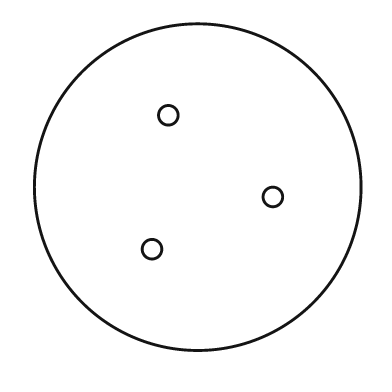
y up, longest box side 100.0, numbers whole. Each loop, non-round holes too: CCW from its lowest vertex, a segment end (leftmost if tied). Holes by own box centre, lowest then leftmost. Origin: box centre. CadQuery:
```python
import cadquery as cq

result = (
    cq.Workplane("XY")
    .moveTo(0.0, 0.0)
    .circle(50.0)
    .moveTo(-14.0, -19.0)
    .circle(3.0)
    .moveTo(23.0, -3.0)
    .circle(3.0)
    .moveTo(-9.0, 22.0)
    .circle(3.0)
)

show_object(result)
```